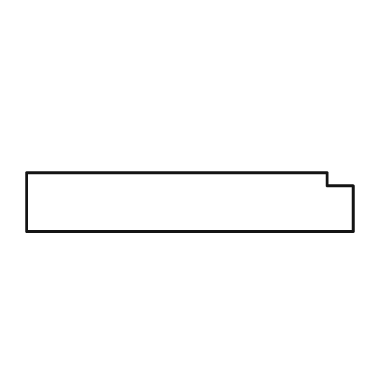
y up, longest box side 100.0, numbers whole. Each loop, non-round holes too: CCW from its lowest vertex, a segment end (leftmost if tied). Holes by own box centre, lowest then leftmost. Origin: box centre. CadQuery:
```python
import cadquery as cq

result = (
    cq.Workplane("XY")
    .moveTo(-50.0, -9.0)
    .lineTo(50.0, -9.0)
    .lineTo(50.0, 5.0)
    .lineTo(42.0, 5.0)
    .lineTo(42.0, 9.0)
    .lineTo(-50.0, 9.0)
    .close()
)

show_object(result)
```